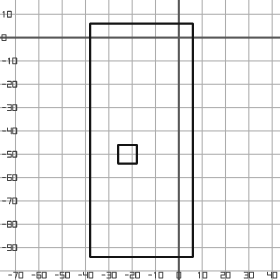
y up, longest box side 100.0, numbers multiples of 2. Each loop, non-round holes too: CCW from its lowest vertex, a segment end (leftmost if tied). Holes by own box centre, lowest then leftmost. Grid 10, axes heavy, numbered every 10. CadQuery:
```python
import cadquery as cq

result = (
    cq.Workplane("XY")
    .moveTo(-38.0, -94.0)
    .lineTo(6.0, -94.0)
    .lineTo(6.0, 6.0)
    .lineTo(-38.0, 6.0)
    .close()
    .moveTo(-26.0, -54.0)
    .lineTo(-18.0, -54.0)
    .lineTo(-18.0, -46.0)
    .lineTo(-26.0, -46.0)
    .close()
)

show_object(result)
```